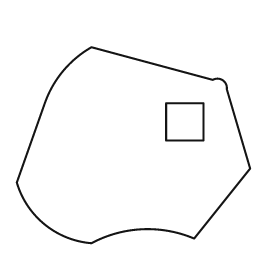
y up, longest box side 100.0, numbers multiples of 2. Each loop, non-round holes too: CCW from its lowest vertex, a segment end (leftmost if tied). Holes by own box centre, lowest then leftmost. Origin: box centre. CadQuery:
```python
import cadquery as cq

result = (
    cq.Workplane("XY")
    .moveTo(-18.0, -42.0)
    .threePointArc((4.0, -36.0), (26.0, -40.0))
    .lineTo(50.0, -10.0)
    .lineTo(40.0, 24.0)
    .threePointArc((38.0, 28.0), (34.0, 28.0))
    .lineTo(-18.0, 42.0)
    .threePointArc((-30.0, 32.0), (-38.0, 18.0))
    .lineTo(-50.0, -16.0)
    .threePointArc((-38.0, -34.0), (-18.0, -42.0))
    .close()
    .moveTo(14.0, 2.0)
    .lineTo(30.0, 2.0)
    .lineTo(30.0, 18.0)
    .lineTo(14.0, 18.0)
    .close()
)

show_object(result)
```